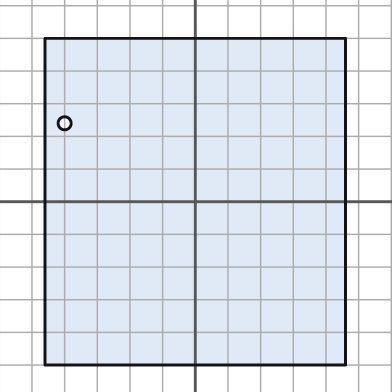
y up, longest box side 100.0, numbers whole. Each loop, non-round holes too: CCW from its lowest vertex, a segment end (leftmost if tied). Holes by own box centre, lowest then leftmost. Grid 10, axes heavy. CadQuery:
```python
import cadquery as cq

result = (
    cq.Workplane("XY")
    .moveTo(-46.0, -50.0)
    .lineTo(46.0, -50.0)
    .lineTo(46.0, 50.0)
    .lineTo(-46.0, 50.0)
    .close()
    .moveTo(-40.0, 24.0)
    .circle(2.0)
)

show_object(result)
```